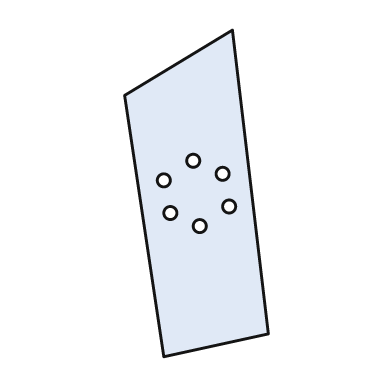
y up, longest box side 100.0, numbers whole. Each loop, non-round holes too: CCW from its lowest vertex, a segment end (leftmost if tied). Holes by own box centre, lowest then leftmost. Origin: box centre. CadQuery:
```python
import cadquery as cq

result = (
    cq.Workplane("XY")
    .moveTo(-10.0, -50.0)
    .lineTo(22.0, -43.0)
    .lineTo(11.0, 50.0)
    .lineTo(-22.0, 30.0)
    .close()
    .moveTo(1.0, -10.0)
    .circle(2.0)
    .moveTo(-8.0, -6.0)
    .circle(2.0)
    .moveTo(10.0, -4.0)
    .circle(2.0)
    .moveTo(-10.0, 4.0)
    .circle(2.0)
    .moveTo(8.0, 6.0)
    .circle(2.0)
    .moveTo(-1.0, 10.0)
    .circle(2.0)
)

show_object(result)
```